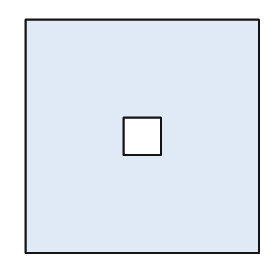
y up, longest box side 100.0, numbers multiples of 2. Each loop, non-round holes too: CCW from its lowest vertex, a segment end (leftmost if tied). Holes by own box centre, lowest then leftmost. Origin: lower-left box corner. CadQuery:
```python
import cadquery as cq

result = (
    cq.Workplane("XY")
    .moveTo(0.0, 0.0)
    .lineTo(100.0, 0.0)
    .lineTo(100.0, 100.0)
    .lineTo(0.0, 100.0)
    .close()
    .moveTo(42.0, 42.0)
    .lineTo(58.0, 42.0)
    .lineTo(58.0, 58.0)
    .lineTo(42.0, 58.0)
    .close()
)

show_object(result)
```